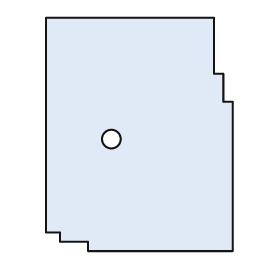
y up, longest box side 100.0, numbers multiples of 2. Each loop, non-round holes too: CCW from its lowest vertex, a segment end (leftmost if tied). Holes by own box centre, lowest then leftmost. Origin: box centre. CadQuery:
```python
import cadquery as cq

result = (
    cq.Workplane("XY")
    .moveTo(-22.0, -50.0)
    .lineTo(40.0, -50.0)
    .lineTo(40.0, 14.0)
    .lineTo(36.0, 14.0)
    .lineTo(36.0, 26.0)
    .lineTo(32.0, 26.0)
    .lineTo(32.0, 50.0)
    .lineTo(-40.0, 50.0)
    .lineTo(-40.0, -42.0)
    .lineTo(-34.0, -42.0)
    .lineTo(-34.0, -46.0)
    .lineTo(-22.0, -46.0)
    .close()
    .moveTo(-12.0, -2.0)
    .circle(4.0)
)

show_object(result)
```